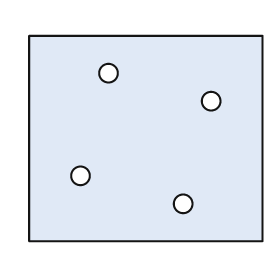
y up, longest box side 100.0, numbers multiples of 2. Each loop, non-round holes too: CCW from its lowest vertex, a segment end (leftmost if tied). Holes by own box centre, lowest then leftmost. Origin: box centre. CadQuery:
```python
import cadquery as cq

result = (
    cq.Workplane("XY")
    .moveTo(-50.0, -44.0)
    .lineTo(50.0, -44.0)
    .lineTo(50.0, 44.0)
    .lineTo(-50.0, 44.0)
    .close()
    .moveTo(16.0, -28.0)
    .circle(4.0)
    .moveTo(-28.0, -16.0)
    .circle(4.0)
    .moveTo(28.0, 16.0)
    .circle(4.0)
    .moveTo(-16.0, 28.0)
    .circle(4.0)
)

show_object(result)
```